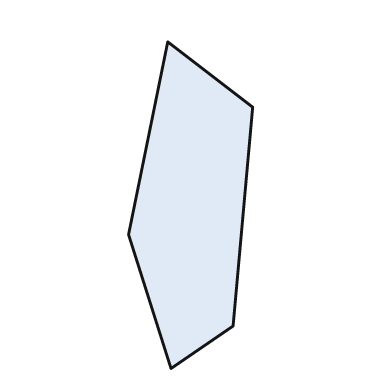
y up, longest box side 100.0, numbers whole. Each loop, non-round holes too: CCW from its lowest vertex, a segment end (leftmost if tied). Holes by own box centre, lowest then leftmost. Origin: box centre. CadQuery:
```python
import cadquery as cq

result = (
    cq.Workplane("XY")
    .moveTo(-6.0, -50.0)
    .lineTo(13.0, -37.0)
    .lineTo(19.0, 30.0)
    .lineTo(-7.0, 50.0)
    .lineTo(-19.0, -9.0)
    .close()
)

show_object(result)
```